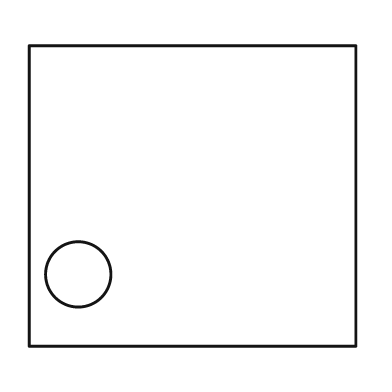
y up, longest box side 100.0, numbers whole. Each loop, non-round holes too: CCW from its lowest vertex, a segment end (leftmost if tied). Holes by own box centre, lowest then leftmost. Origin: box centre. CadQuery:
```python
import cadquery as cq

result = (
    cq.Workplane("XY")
    .moveTo(-50.0, -46.0)
    .lineTo(50.0, -46.0)
    .lineTo(50.0, 46.0)
    .lineTo(-50.0, 46.0)
    .close()
    .moveTo(-35.0, -24.0)
    .circle(10.0)
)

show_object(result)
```